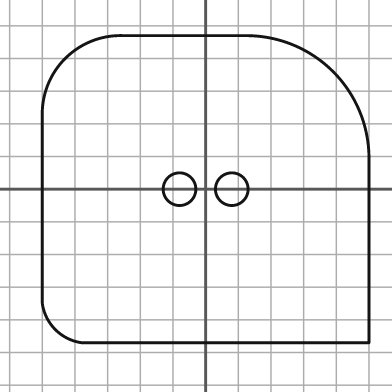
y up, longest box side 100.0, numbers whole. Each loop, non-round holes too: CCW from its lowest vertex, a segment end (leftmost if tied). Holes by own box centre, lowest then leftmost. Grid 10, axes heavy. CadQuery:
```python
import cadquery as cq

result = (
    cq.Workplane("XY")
    .moveTo(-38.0, -47.0)
    .lineTo(50.0, -47.0)
    .lineTo(50.0, 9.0)
    .threePointArc((39.0, 36.0), (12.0, 47.0))
    .lineTo(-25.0, 47.0)
    .threePointArc((-43.0, 40.0), (-50.0, 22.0))
    .lineTo(-50.0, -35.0)
    .threePointArc((-46.0, -43.0), (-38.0, -47.0))
    .close()
    .moveTo(-8.0, 0.0)
    .circle(5.0)
    .moveTo(8.0, 0.0)
    .circle(5.0)
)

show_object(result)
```